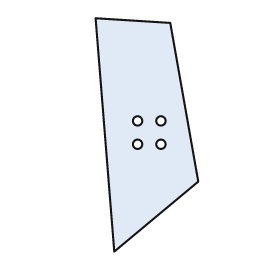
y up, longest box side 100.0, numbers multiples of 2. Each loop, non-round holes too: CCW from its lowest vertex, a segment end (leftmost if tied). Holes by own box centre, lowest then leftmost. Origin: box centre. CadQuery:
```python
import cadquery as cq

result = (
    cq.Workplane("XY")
    .moveTo(-14.0, -50.0)
    .lineTo(22.0, -20.0)
    .lineTo(10.0, 48.0)
    .lineTo(-22.0, 50.0)
    .close()
    .moveTo(-4.0, -4.0)
    .circle(2.0)
    .moveTo(6.0, -4.0)
    .circle(2.0)
    .moveTo(-4.0, 6.0)
    .circle(2.0)
    .moveTo(6.0, 6.0)
    .circle(2.0)
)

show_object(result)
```